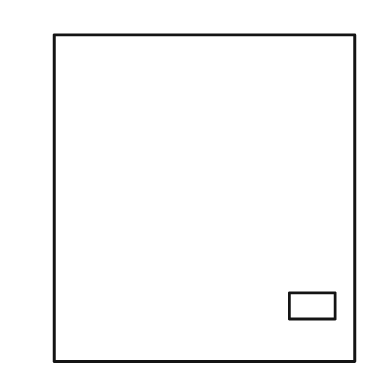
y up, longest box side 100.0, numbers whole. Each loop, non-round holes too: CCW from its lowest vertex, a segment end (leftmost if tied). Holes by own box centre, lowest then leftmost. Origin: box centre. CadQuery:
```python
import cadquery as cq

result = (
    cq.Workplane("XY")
    .moveTo(-46.0, -50.0)
    .lineTo(46.0, -50.0)
    .lineTo(46.0, 50.0)
    .lineTo(-46.0, 50.0)
    .close()
    .moveTo(26.0, -37.0)
    .lineTo(40.0, -37.0)
    .lineTo(40.0, -29.0)
    .lineTo(26.0, -29.0)
    .close()
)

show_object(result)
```